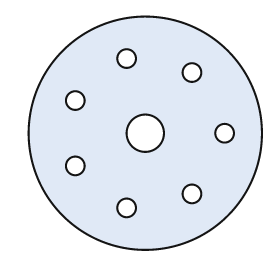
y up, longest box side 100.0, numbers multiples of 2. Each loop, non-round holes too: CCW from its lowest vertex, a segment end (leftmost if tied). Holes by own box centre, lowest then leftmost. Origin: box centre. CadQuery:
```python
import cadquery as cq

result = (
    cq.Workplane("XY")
    .moveTo(0.0, 0.0)
    .circle(50.0)
    .moveTo(-8.0, -32.0)
    .circle(4.0)
    .moveTo(20.0, -26.0)
    .circle(4.0)
    .moveTo(-30.0, -14.0)
    .circle(4.0)
    .moveTo(0.0, 0.0)
    .circle(8.0)
    .moveTo(34.0, 0.0)
    .circle(4.0)
    .moveTo(-30.0, 14.0)
    .circle(4.0)
    .moveTo(20.0, 26.0)
    .circle(4.0)
    .moveTo(-8.0, 32.0)
    .circle(4.0)
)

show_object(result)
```